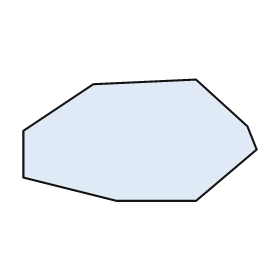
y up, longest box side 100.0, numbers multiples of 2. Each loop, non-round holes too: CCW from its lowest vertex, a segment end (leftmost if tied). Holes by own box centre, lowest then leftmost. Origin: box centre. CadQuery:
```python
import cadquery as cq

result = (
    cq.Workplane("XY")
    .moveTo(-10.0, -26.0)
    .lineTo(24.0, -26.0)
    .lineTo(50.0, -4.0)
    .lineTo(46.0, 6.0)
    .lineTo(24.0, 26.0)
    .lineTo(-20.0, 24.0)
    .lineTo(-50.0, 4.0)
    .lineTo(-50.0, -16.0)
    .close()
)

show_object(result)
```